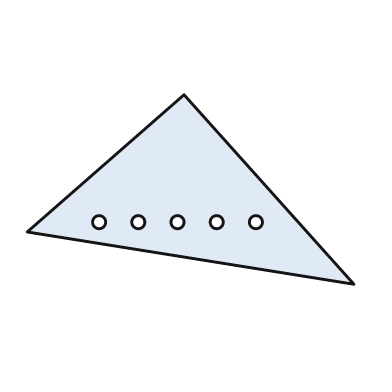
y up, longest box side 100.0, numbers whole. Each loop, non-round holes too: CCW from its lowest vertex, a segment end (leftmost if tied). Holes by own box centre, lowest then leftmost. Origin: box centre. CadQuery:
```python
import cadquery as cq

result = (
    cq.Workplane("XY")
    .moveTo(50.0, -29.0)
    .lineTo(-2.0, 29.0)
    .lineTo(-50.0, -13.0)
    .close()
    .moveTo(-28.0, -10.0)
    .circle(2.0)
    .moveTo(-16.0, -10.0)
    .circle(2.0)
    .moveTo(-4.0, -10.0)
    .circle(2.0)
    .moveTo(8.0, -10.0)
    .circle(2.0)
    .moveTo(20.0, -10.0)
    .circle(2.0)
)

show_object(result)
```